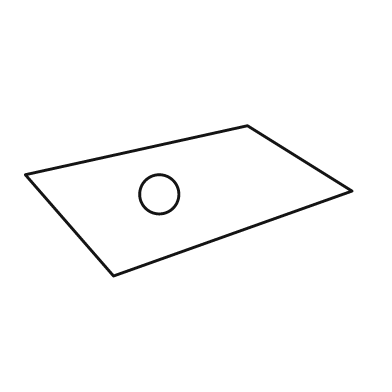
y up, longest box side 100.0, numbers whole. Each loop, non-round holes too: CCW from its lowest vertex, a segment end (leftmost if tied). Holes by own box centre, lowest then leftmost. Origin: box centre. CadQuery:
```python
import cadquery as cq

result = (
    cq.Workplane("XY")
    .moveTo(-23.0, -23.0)
    .lineTo(50.0, 3.0)
    .lineTo(18.0, 23.0)
    .lineTo(-50.0, 8.0)
    .close()
    .moveTo(-9.0, 2.0)
    .circle(6.0)
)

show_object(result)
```